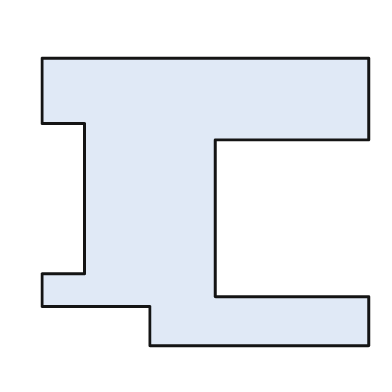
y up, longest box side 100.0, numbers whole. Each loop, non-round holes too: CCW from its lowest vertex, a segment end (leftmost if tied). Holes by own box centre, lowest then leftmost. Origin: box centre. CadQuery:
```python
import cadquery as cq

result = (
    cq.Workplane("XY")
    .moveTo(-17.0, -44.0)
    .lineTo(50.0, -44.0)
    .lineTo(50.0, -29.0)
    .lineTo(3.0, -29.0)
    .lineTo(3.0, 19.0)
    .lineTo(50.0, 19.0)
    .lineTo(50.0, 44.0)
    .lineTo(-50.0, 44.0)
    .lineTo(-50.0, 24.0)
    .lineTo(-37.0, 24.0)
    .lineTo(-37.0, -22.0)
    .lineTo(-50.0, -22.0)
    .lineTo(-50.0, -32.0)
    .lineTo(-17.0, -32.0)
    .close()
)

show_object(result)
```